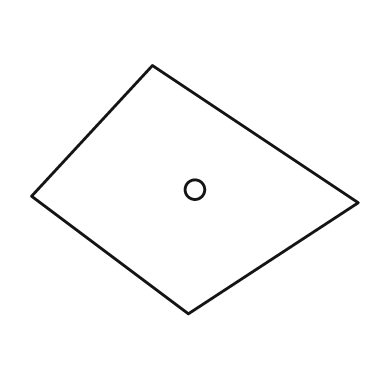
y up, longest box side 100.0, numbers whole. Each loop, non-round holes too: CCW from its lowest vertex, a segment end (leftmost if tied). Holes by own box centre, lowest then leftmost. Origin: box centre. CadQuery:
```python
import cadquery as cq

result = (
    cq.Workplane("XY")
    .moveTo(-2.0, -38.0)
    .lineTo(50.0, -4.0)
    .lineTo(-13.0, 38.0)
    .lineTo(-50.0, -2.0)
    .close()
    .moveTo(0.0, 0.0)
    .circle(3.0)
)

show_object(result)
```